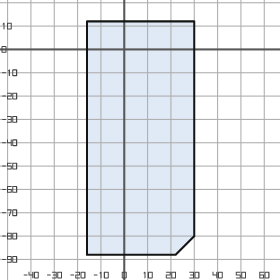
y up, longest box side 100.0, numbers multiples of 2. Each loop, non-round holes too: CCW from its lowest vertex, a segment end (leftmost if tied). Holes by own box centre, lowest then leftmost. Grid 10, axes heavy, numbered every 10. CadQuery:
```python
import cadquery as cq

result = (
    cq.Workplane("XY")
    .moveTo(-16.0, -88.0)
    .lineTo(22.0, -88.0)
    .lineTo(30.0, -80.0)
    .lineTo(30.0, 12.0)
    .lineTo(-16.0, 12.0)
    .close()
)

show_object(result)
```